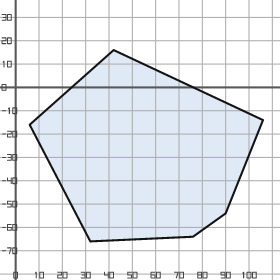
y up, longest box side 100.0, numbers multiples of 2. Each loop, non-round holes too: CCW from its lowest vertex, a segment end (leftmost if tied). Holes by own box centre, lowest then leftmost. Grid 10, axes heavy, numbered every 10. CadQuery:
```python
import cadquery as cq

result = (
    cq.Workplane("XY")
    .moveTo(32.0, -66.0)
    .lineTo(76.0, -64.0)
    .lineTo(90.0, -54.0)
    .lineTo(106.0, -14.0)
    .lineTo(42.0, 16.0)
    .lineTo(6.0, -16.0)
    .close()
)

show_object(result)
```